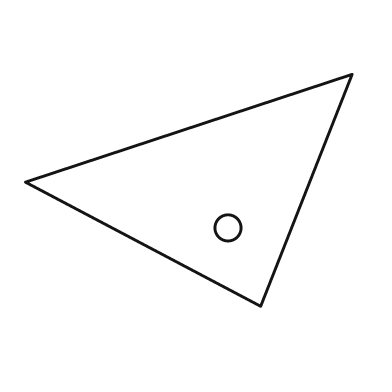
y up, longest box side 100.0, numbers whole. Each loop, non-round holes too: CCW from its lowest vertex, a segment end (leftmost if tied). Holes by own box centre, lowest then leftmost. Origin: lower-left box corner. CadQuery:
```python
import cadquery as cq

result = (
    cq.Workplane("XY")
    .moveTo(72.0, 0.0)
    .lineTo(100.0, 71.0)
    .lineTo(0.0, 38.0)
    .close()
    .moveTo(62.0, 24.0)
    .circle(4.0)
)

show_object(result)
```